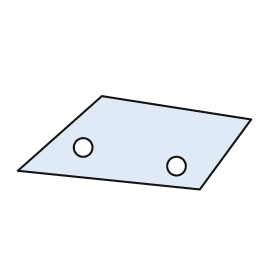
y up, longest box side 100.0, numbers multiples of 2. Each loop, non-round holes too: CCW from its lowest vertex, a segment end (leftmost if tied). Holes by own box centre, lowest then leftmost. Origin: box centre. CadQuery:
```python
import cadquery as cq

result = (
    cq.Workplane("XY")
    .moveTo(28.0, -20.0)
    .lineTo(50.0, 10.0)
    .lineTo(-14.0, 20.0)
    .lineTo(-50.0, -12.0)
    .close()
    .moveTo(18.0, -10.0)
    .circle(4.0)
    .moveTo(-22.0, -2.0)
    .circle(4.0)
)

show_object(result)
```